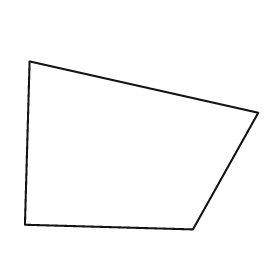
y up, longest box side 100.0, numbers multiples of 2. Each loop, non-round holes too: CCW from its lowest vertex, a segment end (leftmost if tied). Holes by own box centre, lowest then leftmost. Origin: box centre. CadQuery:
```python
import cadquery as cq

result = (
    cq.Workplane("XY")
    .moveTo(22.0, -36.0)
    .lineTo(50.0, 14.0)
    .lineTo(-48.0, 36.0)
    .lineTo(-50.0, -34.0)
    .close()
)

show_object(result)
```